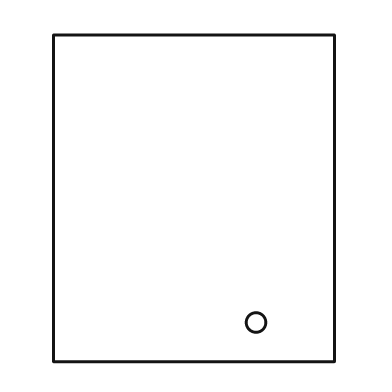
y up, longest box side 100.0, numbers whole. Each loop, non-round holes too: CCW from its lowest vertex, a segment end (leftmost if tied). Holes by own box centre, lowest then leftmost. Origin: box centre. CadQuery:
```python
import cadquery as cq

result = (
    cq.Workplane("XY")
    .moveTo(-43.0, -50.0)
    .lineTo(43.0, -50.0)
    .lineTo(43.0, 50.0)
    .lineTo(-43.0, 50.0)
    .close()
    .moveTo(19.0, -38.0)
    .circle(3.0)
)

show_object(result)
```